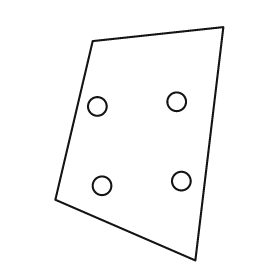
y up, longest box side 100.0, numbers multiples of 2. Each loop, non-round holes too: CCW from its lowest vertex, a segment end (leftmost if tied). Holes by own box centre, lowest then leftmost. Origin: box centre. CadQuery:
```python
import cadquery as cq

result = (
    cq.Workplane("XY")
    .moveTo(24.0, -50.0)
    .lineTo(36.0, 50.0)
    .lineTo(-20.0, 44.0)
    .lineTo(-36.0, -24.0)
    .close()
    .moveTo(-16.0, -18.0)
    .circle(4.0)
    .moveTo(18.0, -16.0)
    .circle(4.0)
    .moveTo(-18.0, 16.0)
    .circle(4.0)
    .moveTo(16.0, 18.0)
    .circle(4.0)
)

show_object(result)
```